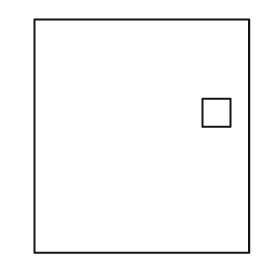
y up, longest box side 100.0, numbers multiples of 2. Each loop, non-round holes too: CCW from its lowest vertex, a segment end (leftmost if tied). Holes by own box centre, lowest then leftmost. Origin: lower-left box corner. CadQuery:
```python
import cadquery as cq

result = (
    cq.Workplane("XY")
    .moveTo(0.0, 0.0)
    .lineTo(92.0, 0.0)
    .lineTo(92.0, 100.0)
    .lineTo(0.0, 100.0)
    .close()
    .moveTo(72.0, 54.0)
    .lineTo(84.0, 54.0)
    .lineTo(84.0, 66.0)
    .lineTo(72.0, 66.0)
    .close()
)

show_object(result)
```